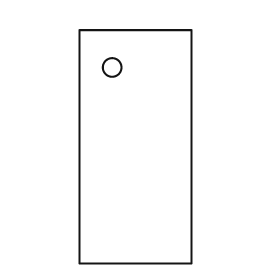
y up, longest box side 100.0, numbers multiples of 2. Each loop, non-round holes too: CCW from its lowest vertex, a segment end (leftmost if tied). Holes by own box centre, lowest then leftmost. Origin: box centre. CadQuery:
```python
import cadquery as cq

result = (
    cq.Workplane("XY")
    .moveTo(-24.0, -50.0)
    .lineTo(24.0, -50.0)
    .lineTo(24.0, 50.0)
    .lineTo(-24.0, 50.0)
    .close()
    .moveTo(-10.0, 34.0)
    .circle(4.0)
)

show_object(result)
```